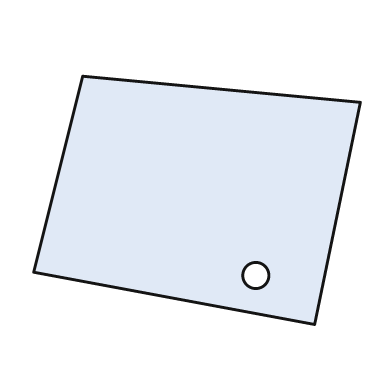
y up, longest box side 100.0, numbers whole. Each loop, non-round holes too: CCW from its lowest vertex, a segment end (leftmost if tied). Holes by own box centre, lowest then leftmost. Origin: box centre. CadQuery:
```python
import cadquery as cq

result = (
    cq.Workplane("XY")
    .moveTo(36.0, -38.0)
    .lineTo(50.0, 30.0)
    .lineTo(-35.0, 38.0)
    .lineTo(-50.0, -22.0)
    .close()
    .moveTo(18.0, -23.0)
    .circle(4.0)
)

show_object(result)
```